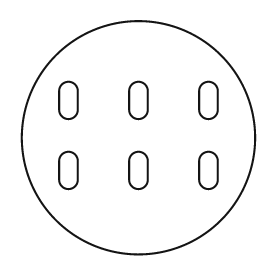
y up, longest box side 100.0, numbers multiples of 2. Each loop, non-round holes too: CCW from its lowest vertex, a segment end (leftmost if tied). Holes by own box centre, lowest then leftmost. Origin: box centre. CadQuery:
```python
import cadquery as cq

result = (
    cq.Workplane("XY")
    .moveTo(0.0, 0.0)
    .circle(50.0)
    .moveTo(-34.0, -18.0)
    .threePointArc((-30.0, -22.0), (-26.0, -18.0))
    .lineTo(-26.0, -10.0)
    .threePointArc((-30.0, -6.0), (-34.0, -10.0))
    .close()
    .moveTo(-4.0, -18.0)
    .threePointArc((0.0, -22.0), (4.0, -18.0))
    .lineTo(4.0, -10.0)
    .threePointArc((0.0, -6.0), (-4.0, -10.0))
    .close()
    .moveTo(26.0, -18.0)
    .threePointArc((30.0, -22.0), (34.0, -18.0))
    .lineTo(34.0, -10.0)
    .threePointArc((30.0, -6.0), (26.0, -10.0))
    .close()
    .moveTo(-34.0, 12.0)
    .threePointArc((-30.0, 8.0), (-26.0, 12.0))
    .lineTo(-26.0, 20.0)
    .threePointArc((-30.0, 24.0), (-34.0, 20.0))
    .close()
    .moveTo(-4.0, 12.0)
    .threePointArc((0.0, 8.0), (4.0, 12.0))
    .lineTo(4.0, 20.0)
    .threePointArc((0.0, 24.0), (-4.0, 20.0))
    .close()
    .moveTo(26.0, 12.0)
    .threePointArc((30.0, 8.0), (34.0, 12.0))
    .lineTo(34.0, 20.0)
    .threePointArc((30.0, 24.0), (26.0, 20.0))
    .close()
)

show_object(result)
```